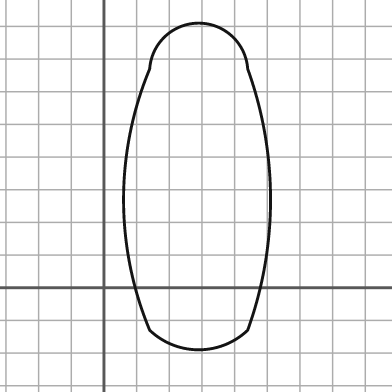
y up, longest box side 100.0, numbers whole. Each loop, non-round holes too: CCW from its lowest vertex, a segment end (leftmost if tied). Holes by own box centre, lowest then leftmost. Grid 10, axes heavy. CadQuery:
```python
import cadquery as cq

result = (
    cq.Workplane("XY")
    .moveTo(14.0, -13.0)
    .threePointArc((29.0, -19.0), (44.0, -13.0))
    .threePointArc((51.0, 27.0), (44.0, 67.0))
    .threePointArc((29.0, 81.0), (14.0, 67.0))
    .threePointArc((6.0, 27.0), (14.0, -13.0))
    .close()
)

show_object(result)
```